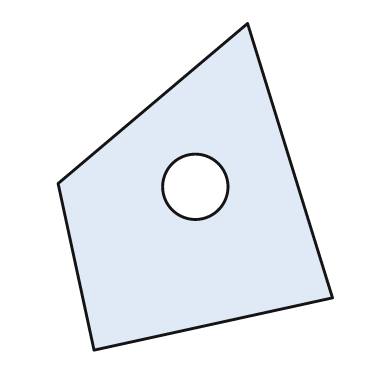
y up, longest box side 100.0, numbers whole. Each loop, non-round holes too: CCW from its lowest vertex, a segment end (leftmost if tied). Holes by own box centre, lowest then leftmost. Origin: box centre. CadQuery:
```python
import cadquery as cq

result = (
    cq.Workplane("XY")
    .moveTo(-31.0, -50.0)
    .lineTo(42.0, -34.0)
    .lineTo(16.0, 50.0)
    .lineTo(-42.0, 1.0)
    .close()
    .moveTo(0.0, 0.0)
    .circle(10.0)
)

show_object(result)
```